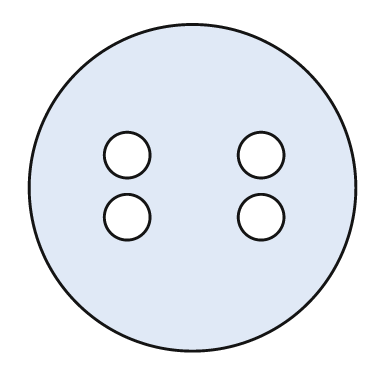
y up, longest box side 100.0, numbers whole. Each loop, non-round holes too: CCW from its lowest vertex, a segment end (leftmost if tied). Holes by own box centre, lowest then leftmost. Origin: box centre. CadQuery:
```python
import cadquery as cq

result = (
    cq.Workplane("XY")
    .moveTo(0.0, 0.0)
    .circle(50.0)
    .moveTo(-20.0, -9.0)
    .circle(7.0)
    .moveTo(21.0, -9.0)
    .circle(7.0)
    .moveTo(-20.0, 10.0)
    .circle(7.0)
    .moveTo(21.0, 10.0)
    .circle(7.0)
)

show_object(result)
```